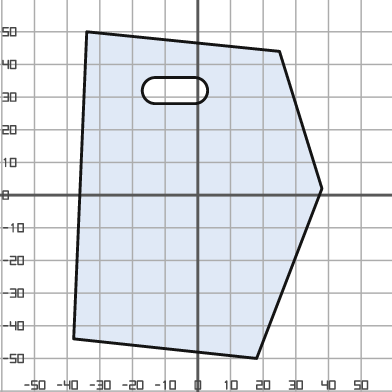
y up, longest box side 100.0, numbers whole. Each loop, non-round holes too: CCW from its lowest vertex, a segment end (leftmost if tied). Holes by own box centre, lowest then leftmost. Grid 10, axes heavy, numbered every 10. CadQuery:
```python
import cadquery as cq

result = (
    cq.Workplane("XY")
    .moveTo(18.0, -50.0)
    .lineTo(38.0, 2.0)
    .lineTo(25.0, 44.0)
    .lineTo(-34.0, 50.0)
    .lineTo(-38.0, -44.0)
    .close()
    .moveTo(-13.0, 28.0)
    .lineTo(-1.0, 28.0)
    .threePointArc((3.0, 32.0), (-1.0, 36.0))
    .lineTo(-13.0, 36.0)
    .threePointArc((-17.0, 32.0), (-13.0, 28.0))
    .close()
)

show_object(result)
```